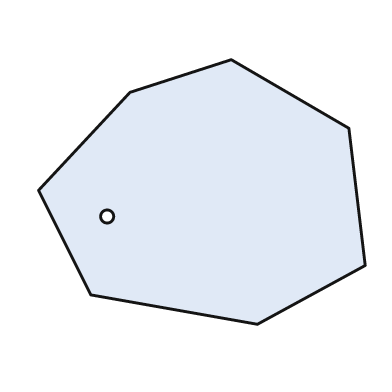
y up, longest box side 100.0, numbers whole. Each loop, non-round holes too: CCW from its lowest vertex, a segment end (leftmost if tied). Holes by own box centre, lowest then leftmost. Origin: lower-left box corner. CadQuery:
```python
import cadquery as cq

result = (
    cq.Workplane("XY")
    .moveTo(67.0, 0.0)
    .lineTo(100.0, 18.0)
    .lineTo(95.0, 60.0)
    .lineTo(59.0, 81.0)
    .lineTo(28.0, 71.0)
    .lineTo(0.0, 41.0)
    .lineTo(16.0, 9.0)
    .close()
    .moveTo(21.0, 33.0)
    .circle(2.0)
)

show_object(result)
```